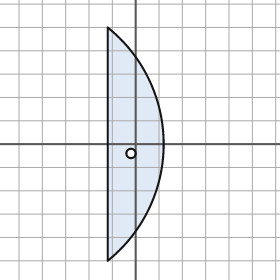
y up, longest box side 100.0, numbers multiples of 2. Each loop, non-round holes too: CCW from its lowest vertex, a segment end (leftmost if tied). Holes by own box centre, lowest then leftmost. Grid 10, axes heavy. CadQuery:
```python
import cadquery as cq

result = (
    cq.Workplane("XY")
    .moveTo(-12.0, -50.0)
    .threePointArc((12.0, 0.0), (-12.0, 50.0))
    .close()
    .moveTo(-2.0, -4.0)
    .circle(2.0)
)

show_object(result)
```